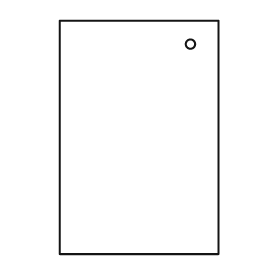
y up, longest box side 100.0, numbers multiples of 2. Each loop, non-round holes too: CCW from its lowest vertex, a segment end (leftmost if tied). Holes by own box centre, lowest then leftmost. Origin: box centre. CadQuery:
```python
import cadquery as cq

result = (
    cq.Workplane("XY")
    .moveTo(-34.0, -50.0)
    .lineTo(34.0, -50.0)
    .lineTo(34.0, 50.0)
    .lineTo(-34.0, 50.0)
    .close()
    .moveTo(22.0, 40.0)
    .circle(2.0)
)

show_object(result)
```